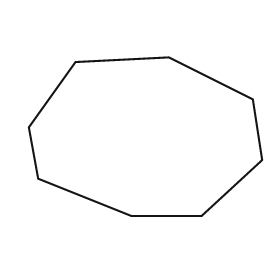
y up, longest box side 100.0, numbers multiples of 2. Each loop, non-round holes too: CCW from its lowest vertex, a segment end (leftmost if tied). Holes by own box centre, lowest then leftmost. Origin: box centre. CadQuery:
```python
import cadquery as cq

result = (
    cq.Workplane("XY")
    .moveTo(-6.0, -34.0)
    .lineTo(24.0, -34.0)
    .lineTo(50.0, -10.0)
    .lineTo(46.0, 16.0)
    .lineTo(10.0, 34.0)
    .lineTo(-30.0, 32.0)
    .lineTo(-50.0, 4.0)
    .lineTo(-46.0, -18.0)
    .close()
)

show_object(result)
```